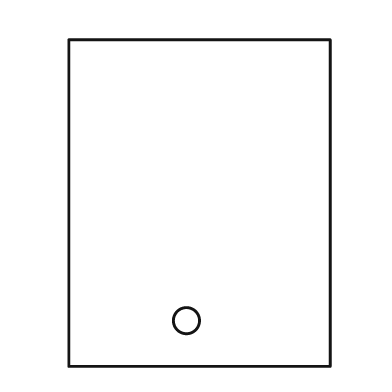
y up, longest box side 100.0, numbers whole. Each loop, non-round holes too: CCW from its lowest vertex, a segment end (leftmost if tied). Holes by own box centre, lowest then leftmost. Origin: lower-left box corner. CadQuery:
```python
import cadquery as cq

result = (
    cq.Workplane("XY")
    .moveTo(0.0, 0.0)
    .lineTo(80.0, 0.0)
    .lineTo(80.0, 100.0)
    .lineTo(0.0, 100.0)
    .close()
    .moveTo(36.0, 14.0)
    .circle(4.0)
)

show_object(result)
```